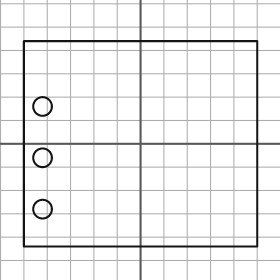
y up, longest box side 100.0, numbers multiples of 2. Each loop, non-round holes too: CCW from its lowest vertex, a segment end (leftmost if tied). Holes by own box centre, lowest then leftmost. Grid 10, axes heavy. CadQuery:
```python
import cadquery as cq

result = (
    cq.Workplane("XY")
    .moveTo(-50.0, -44.0)
    .lineTo(50.0, -44.0)
    .lineTo(50.0, 44.0)
    .lineTo(-50.0, 44.0)
    .close()
    .moveTo(-42.0, -28.0)
    .circle(4.0)
    .moveTo(-42.0, -6.0)
    .circle(4.0)
    .moveTo(-42.0, 16.0)
    .circle(4.0)
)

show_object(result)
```